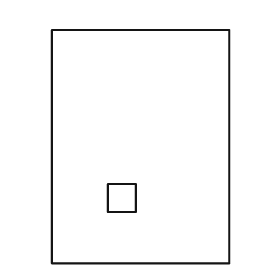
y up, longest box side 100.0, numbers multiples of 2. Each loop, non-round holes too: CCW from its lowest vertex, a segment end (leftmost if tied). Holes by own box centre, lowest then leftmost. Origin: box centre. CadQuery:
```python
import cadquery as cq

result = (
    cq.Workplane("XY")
    .moveTo(-38.0, -50.0)
    .lineTo(38.0, -50.0)
    .lineTo(38.0, 50.0)
    .lineTo(-38.0, 50.0)
    .close()
    .moveTo(-14.0, -28.0)
    .lineTo(-2.0, -28.0)
    .lineTo(-2.0, -16.0)
    .lineTo(-14.0, -16.0)
    .close()
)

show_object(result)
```